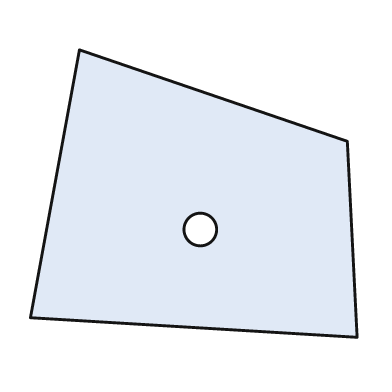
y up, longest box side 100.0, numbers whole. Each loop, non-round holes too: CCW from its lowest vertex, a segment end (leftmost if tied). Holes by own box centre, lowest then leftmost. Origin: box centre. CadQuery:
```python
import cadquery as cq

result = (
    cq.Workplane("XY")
    .moveTo(50.0, -44.0)
    .lineTo(47.0, 16.0)
    .lineTo(-35.0, 44.0)
    .lineTo(-50.0, -38.0)
    .close()
    .moveTo(2.0, -11.0)
    .circle(5.0)
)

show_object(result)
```